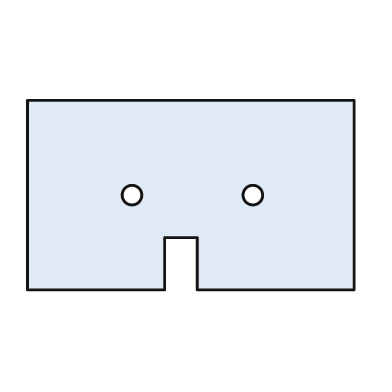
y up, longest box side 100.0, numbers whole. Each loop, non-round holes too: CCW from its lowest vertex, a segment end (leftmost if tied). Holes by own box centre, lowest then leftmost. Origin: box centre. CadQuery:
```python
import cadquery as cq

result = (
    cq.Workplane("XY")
    .moveTo(-50.0, -29.0)
    .lineTo(-8.0, -29.0)
    .lineTo(-8.0, -13.0)
    .lineTo(2.0, -13.0)
    .lineTo(2.0, -29.0)
    .lineTo(50.0, -29.0)
    .lineTo(50.0, 29.0)
    .lineTo(-50.0, 29.0)
    .close()
    .moveTo(-18.0, 0.0)
    .circle(3.0)
    .moveTo(19.0, 0.0)
    .circle(3.0)
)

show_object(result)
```